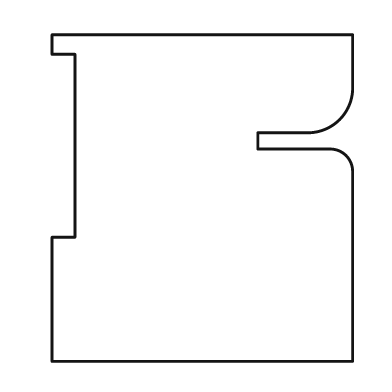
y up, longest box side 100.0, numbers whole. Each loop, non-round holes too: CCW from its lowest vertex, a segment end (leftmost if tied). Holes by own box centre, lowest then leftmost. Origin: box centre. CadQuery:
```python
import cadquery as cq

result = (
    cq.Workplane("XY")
    .moveTo(-46.0, -50.0)
    .lineTo(46.0, -50.0)
    .lineTo(46.0, 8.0)
    .threePointArc((44.0, 13.0), (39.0, 15.0))
    .lineTo(17.0, 15.0)
    .lineTo(17.0, 20.0)
    .lineTo(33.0, 20.0)
    .threePointArc((42.0, 24.0), (46.0, 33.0))
    .lineTo(46.0, 50.0)
    .lineTo(-46.0, 50.0)
    .lineTo(-46.0, 44.0)
    .lineTo(-39.0, 44.0)
    .lineTo(-39.0, -12.0)
    .lineTo(-46.0, -12.0)
    .close()
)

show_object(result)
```